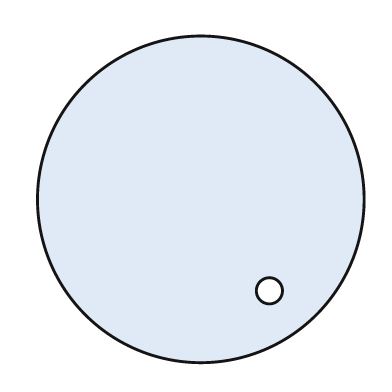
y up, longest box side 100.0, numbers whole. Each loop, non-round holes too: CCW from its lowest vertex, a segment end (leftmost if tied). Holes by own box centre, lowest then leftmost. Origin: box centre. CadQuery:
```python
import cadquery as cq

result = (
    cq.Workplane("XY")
    .moveTo(0.0, 0.0)
    .circle(50.0)
    .moveTo(21.0, -28.0)
    .circle(4.0)
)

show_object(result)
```